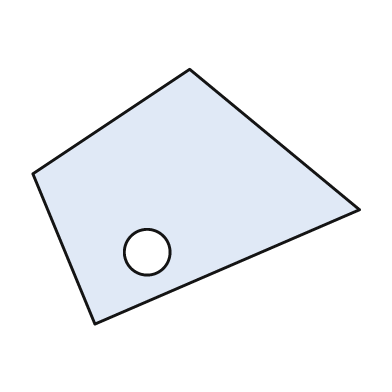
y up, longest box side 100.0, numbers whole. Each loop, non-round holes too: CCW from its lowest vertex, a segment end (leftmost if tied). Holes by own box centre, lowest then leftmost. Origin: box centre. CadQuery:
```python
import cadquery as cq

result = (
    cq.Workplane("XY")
    .moveTo(-31.0, -39.0)
    .lineTo(50.0, -4.0)
    .lineTo(-2.0, 39.0)
    .lineTo(-50.0, 7.0)
    .close()
    .moveTo(-15.0, -17.0)
    .circle(7.0)
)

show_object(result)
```